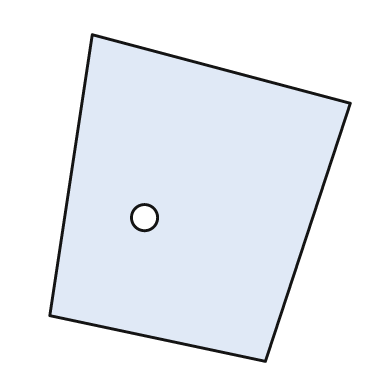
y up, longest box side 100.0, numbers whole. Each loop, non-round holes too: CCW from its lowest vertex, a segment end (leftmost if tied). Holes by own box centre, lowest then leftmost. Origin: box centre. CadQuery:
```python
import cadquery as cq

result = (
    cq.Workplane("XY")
    .moveTo(20.0, -50.0)
    .lineTo(46.0, 29.0)
    .lineTo(-33.0, 50.0)
    .lineTo(-46.0, -36.0)
    .close()
    .moveTo(-17.0, -6.0)
    .circle(4.0)
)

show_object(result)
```